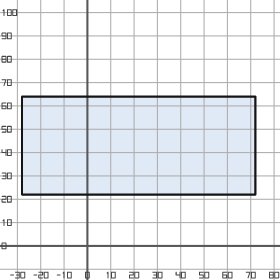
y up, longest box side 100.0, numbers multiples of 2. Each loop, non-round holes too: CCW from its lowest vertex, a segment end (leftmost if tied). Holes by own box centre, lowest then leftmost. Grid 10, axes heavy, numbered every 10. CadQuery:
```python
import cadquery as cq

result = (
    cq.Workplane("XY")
    .moveTo(-28.0, 22.0)
    .lineTo(72.0, 22.0)
    .lineTo(72.0, 64.0)
    .lineTo(-28.0, 64.0)
    .close()
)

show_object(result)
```